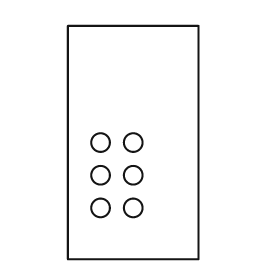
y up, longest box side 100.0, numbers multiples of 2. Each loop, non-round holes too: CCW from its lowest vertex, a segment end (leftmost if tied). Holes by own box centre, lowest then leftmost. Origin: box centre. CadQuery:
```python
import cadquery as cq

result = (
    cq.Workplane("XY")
    .moveTo(-28.0, -50.0)
    .lineTo(28.0, -50.0)
    .lineTo(28.0, 50.0)
    .lineTo(-28.0, 50.0)
    .close()
    .moveTo(-14.0, -28.0)
    .circle(4.0)
    .moveTo(0.0, -28.0)
    .circle(4.0)
    .moveTo(-14.0, -14.0)
    .circle(4.0)
    .moveTo(0.0, -14.0)
    .circle(4.0)
    .moveTo(-14.0, 0.0)
    .circle(4.0)
    .moveTo(0.0, 0.0)
    .circle(4.0)
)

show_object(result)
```